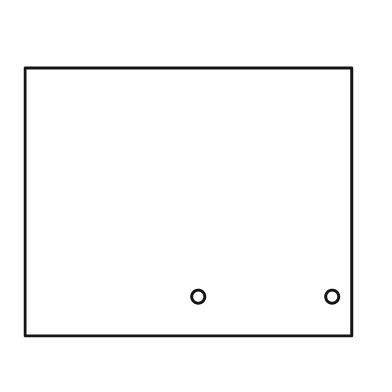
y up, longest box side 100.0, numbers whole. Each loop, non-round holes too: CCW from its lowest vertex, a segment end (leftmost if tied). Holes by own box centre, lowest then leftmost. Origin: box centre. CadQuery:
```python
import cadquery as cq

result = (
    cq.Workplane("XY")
    .moveTo(-50.0, -41.0)
    .lineTo(50.0, -41.0)
    .lineTo(50.0, 41.0)
    .lineTo(-50.0, 41.0)
    .close()
    .moveTo(3.0, -29.0)
    .circle(2.0)
    .moveTo(44.0, -29.0)
    .circle(2.0)
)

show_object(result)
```